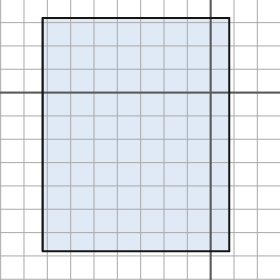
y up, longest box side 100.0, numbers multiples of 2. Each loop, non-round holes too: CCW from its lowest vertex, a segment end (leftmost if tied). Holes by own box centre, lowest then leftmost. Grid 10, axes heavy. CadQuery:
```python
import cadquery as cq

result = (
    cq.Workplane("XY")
    .moveTo(-72.0, -68.0)
    .lineTo(8.0, -68.0)
    .lineTo(8.0, 32.0)
    .lineTo(-72.0, 32.0)
    .close()
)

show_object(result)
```